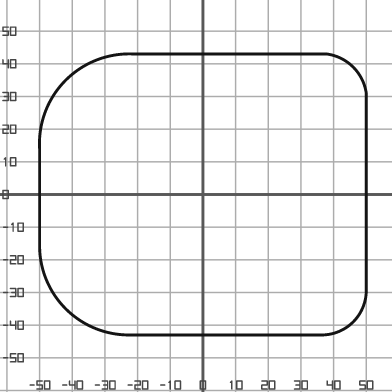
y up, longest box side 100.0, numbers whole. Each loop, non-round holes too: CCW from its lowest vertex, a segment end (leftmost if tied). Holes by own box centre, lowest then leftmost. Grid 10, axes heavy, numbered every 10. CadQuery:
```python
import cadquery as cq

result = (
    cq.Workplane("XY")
    .moveTo(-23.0, -43.0)
    .lineTo(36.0, -43.0)
    .threePointArc((46.0, -39.0), (50.0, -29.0))
    .lineTo(50.0, 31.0)
    .threePointArc((46.0, 39.0), (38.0, 43.0))
    .lineTo(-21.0, 43.0)
    .threePointArc((-42.0, 35.0), (-50.0, 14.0))
    .lineTo(-50.0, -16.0)
    .threePointArc((-42.0, -35.0), (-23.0, -43.0))
    .close()
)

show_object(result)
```